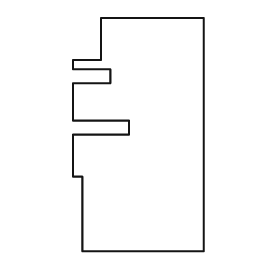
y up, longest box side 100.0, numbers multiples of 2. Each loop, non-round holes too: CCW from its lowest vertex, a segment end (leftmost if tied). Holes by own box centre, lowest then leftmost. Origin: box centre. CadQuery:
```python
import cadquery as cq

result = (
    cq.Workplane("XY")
    .moveTo(-24.0, -50.0)
    .lineTo(28.0, -50.0)
    .lineTo(28.0, 50.0)
    .lineTo(-16.0, 50.0)
    .lineTo(-16.0, 32.0)
    .lineTo(-28.0, 32.0)
    .lineTo(-28.0, 28.0)
    .lineTo(-12.0, 28.0)
    .lineTo(-12.0, 22.0)
    .lineTo(-28.0, 22.0)
    .lineTo(-28.0, 6.0)
    .lineTo(-4.0, 6.0)
    .lineTo(-4.0, 0.0)
    .lineTo(-28.0, 0.0)
    .lineTo(-28.0, -18.0)
    .lineTo(-24.0, -18.0)
    .close()
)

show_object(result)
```